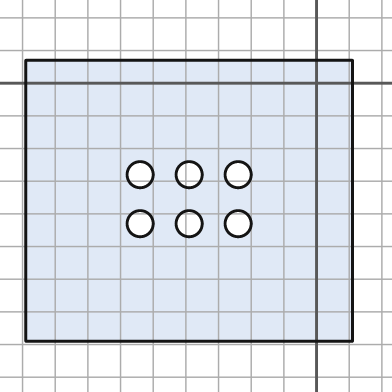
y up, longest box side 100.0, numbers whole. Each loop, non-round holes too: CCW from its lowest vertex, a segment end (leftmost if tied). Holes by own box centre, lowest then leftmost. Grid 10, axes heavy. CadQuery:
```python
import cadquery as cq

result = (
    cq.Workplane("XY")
    .moveTo(-89.0, -79.0)
    .lineTo(11.0, -79.0)
    .lineTo(11.0, 7.0)
    .lineTo(-89.0, 7.0)
    .close()
    .moveTo(-54.0, -43.0)
    .circle(4.0)
    .moveTo(-39.0, -43.0)
    .circle(4.0)
    .moveTo(-24.0, -43.0)
    .circle(4.0)
    .moveTo(-54.0, -28.0)
    .circle(4.0)
    .moveTo(-39.0, -28.0)
    .circle(4.0)
    .moveTo(-24.0, -28.0)
    .circle(4.0)
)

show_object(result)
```